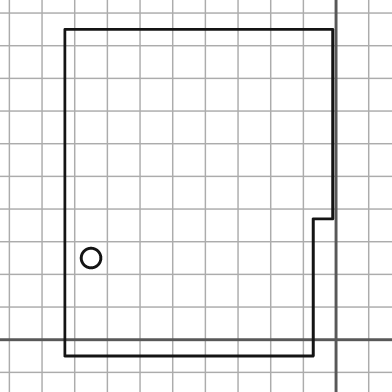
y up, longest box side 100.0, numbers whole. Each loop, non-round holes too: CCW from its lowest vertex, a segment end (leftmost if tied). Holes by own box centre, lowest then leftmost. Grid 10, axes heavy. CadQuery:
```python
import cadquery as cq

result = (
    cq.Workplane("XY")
    .moveTo(-83.0, -5.0)
    .lineTo(-7.0, -5.0)
    .lineTo(-7.0, 37.0)
    .lineTo(-1.0, 37.0)
    .lineTo(-1.0, 95.0)
    .lineTo(-83.0, 95.0)
    .close()
    .moveTo(-75.0, 25.0)
    .circle(3.0)
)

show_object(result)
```